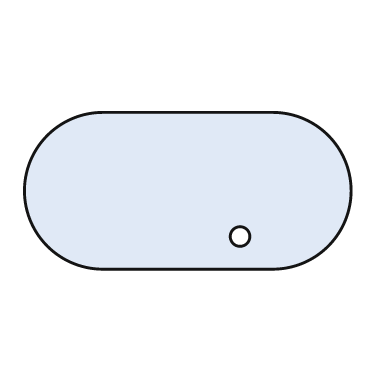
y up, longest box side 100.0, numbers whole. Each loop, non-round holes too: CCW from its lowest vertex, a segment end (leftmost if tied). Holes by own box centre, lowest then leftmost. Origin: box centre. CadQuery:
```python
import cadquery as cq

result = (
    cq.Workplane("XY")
    .moveTo(-26.0, -24.0)
    .lineTo(26.0, -24.0)
    .threePointArc((50.0, 0.0), (26.0, 24.0))
    .lineTo(-26.0, 24.0)
    .threePointArc((-50.0, 0.0), (-26.0, -24.0))
    .close()
    .moveTo(16.0, -14.0)
    .circle(3.0)
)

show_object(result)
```